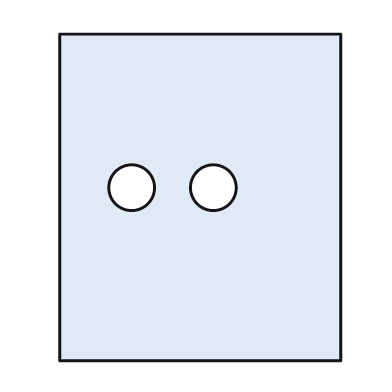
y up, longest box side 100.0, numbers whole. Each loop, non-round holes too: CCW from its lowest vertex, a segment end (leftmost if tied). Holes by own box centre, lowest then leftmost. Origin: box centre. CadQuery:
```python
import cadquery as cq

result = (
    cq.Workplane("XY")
    .moveTo(-43.0, -50.0)
    .lineTo(43.0, -50.0)
    .lineTo(43.0, 50.0)
    .lineTo(-43.0, 50.0)
    .close()
    .moveTo(-21.0, 3.0)
    .circle(7.0)
    .moveTo(4.0, 3.0)
    .circle(7.0)
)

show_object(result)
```